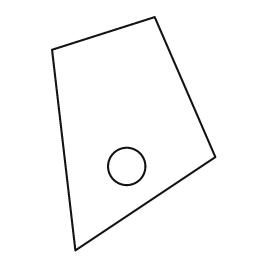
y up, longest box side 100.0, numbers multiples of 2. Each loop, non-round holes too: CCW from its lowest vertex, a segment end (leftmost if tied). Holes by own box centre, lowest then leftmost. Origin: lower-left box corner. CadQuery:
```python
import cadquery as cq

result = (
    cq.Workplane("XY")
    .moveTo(10.0, 0.0)
    .lineTo(70.0, 40.0)
    .lineTo(44.0, 100.0)
    .lineTo(0.0, 86.0)
    .close()
    .moveTo(32.0, 36.0)
    .circle(8.0)
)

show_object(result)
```